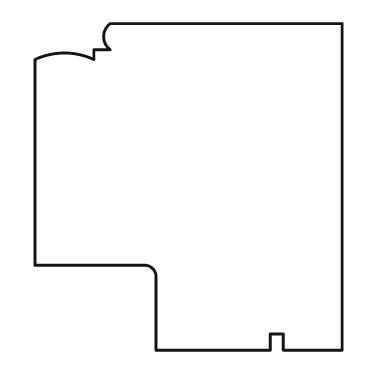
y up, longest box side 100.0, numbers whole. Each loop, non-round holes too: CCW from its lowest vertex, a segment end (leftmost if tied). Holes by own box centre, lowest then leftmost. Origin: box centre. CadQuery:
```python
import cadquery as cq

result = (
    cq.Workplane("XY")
    .moveTo(-10.0, -50.0)
    .lineTo(25.0, -50.0)
    .lineTo(25.0, -45.0)
    .lineTo(29.0, -45.0)
    .lineTo(29.0, -50.0)
    .lineTo(47.0, -50.0)
    .lineTo(47.0, 50.0)
    .lineTo(-24.0, 50.0)
    .threePointArc((-26.0, 46.0), (-24.0, 42.0))
    .lineTo(-29.0, 42.0)
    .lineTo(-29.0, 39.0)
    .threePointArc((-38.0, 41.0), (-47.0, 39.0))
    .lineTo(-47.0, -24.0)
    .lineTo(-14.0, -24.0)
    .threePointArc((-11.0, -25.0), (-10.0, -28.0))
    .close()
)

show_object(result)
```